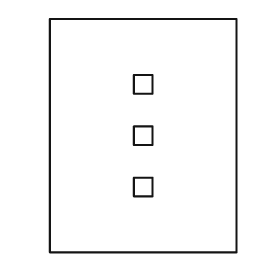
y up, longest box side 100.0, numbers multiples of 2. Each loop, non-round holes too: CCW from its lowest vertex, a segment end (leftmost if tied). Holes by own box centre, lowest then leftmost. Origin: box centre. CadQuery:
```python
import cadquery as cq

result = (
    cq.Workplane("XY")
    .moveTo(-40.0, -50.0)
    .lineTo(40.0, -50.0)
    .lineTo(40.0, 50.0)
    .lineTo(-40.0, 50.0)
    .close()
    .moveTo(-4.0, -26.0)
    .lineTo(4.0, -26.0)
    .lineTo(4.0, -18.0)
    .lineTo(-4.0, -18.0)
    .close()
    .moveTo(-4.0, -4.0)
    .lineTo(4.0, -4.0)
    .lineTo(4.0, 4.0)
    .lineTo(-4.0, 4.0)
    .close()
    .moveTo(-4.0, 18.0)
    .lineTo(4.0, 18.0)
    .lineTo(4.0, 26.0)
    .lineTo(-4.0, 26.0)
    .close()
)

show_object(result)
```